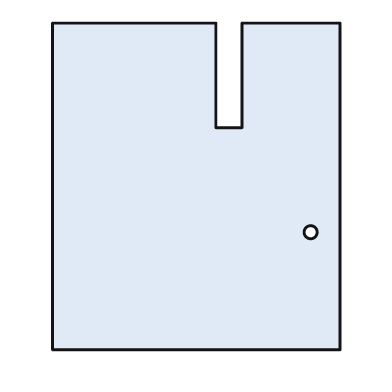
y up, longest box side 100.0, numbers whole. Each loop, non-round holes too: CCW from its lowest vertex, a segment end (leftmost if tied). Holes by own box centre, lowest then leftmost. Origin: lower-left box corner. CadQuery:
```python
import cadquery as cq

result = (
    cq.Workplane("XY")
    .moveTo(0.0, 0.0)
    .lineTo(88.0, 0.0)
    .lineTo(88.0, 100.0)
    .lineTo(58.0, 100.0)
    .lineTo(58.0, 68.0)
    .lineTo(50.0, 68.0)
    .lineTo(50.0, 100.0)
    .lineTo(0.0, 100.0)
    .close()
    .moveTo(79.0, 36.0)
    .circle(2.0)
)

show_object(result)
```